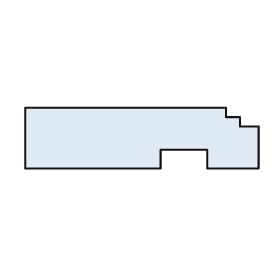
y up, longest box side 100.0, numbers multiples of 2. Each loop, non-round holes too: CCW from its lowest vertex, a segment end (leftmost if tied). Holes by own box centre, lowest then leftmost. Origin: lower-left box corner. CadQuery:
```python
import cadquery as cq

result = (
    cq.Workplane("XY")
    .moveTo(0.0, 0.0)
    .lineTo(58.0, 0.0)
    .lineTo(58.0, 8.0)
    .lineTo(78.0, 8.0)
    .lineTo(78.0, 0.0)
    .lineTo(100.0, 0.0)
    .lineTo(100.0, 18.0)
    .lineTo(92.0, 18.0)
    .lineTo(92.0, 22.0)
    .lineTo(86.0, 22.0)
    .lineTo(86.0, 26.0)
    .lineTo(0.0, 26.0)
    .close()
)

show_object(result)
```